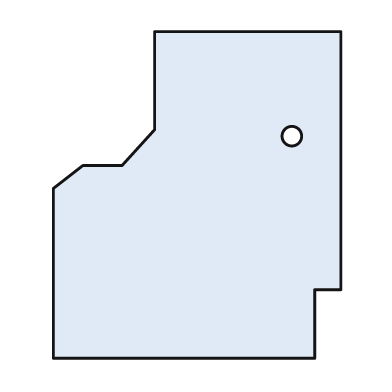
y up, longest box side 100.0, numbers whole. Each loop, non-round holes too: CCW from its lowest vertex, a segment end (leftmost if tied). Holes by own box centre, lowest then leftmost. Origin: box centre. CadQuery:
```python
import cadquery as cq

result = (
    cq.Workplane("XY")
    .moveTo(-44.0, -50.0)
    .lineTo(36.0, -50.0)
    .lineTo(36.0, -29.0)
    .lineTo(44.0, -29.0)
    .lineTo(44.0, 50.0)
    .lineTo(-13.0, 50.0)
    .lineTo(-13.0, 20.0)
    .lineTo(-23.0, 9.0)
    .lineTo(-35.0, 9.0)
    .lineTo(-44.0, 2.0)
    .close()
    .moveTo(29.0, 18.0)
    .circle(3.0)
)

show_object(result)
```